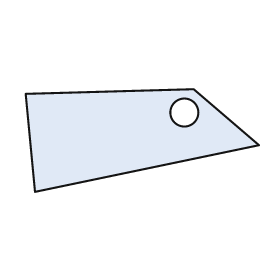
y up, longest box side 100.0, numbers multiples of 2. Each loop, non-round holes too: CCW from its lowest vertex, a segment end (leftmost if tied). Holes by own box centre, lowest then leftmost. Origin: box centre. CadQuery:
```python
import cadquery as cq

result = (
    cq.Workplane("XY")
    .moveTo(-46.0, -22.0)
    .lineTo(50.0, -2.0)
    .lineTo(22.0, 22.0)
    .lineTo(-50.0, 20.0)
    .close()
    .moveTo(18.0, 12.0)
    .circle(6.0)
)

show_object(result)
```